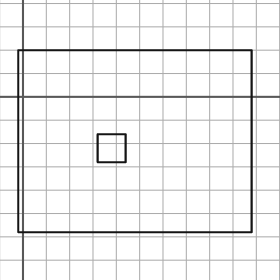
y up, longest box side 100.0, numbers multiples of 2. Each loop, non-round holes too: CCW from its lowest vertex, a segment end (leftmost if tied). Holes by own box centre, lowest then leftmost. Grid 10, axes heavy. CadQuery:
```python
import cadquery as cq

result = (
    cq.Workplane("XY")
    .moveTo(-2.0, -58.0)
    .lineTo(98.0, -58.0)
    .lineTo(98.0, 20.0)
    .lineTo(-2.0, 20.0)
    .close()
    .moveTo(32.0, -28.0)
    .lineTo(44.0, -28.0)
    .lineTo(44.0, -16.0)
    .lineTo(32.0, -16.0)
    .close()
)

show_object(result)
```